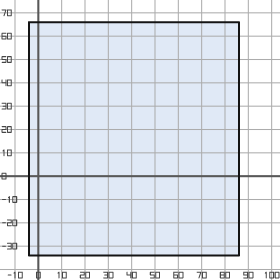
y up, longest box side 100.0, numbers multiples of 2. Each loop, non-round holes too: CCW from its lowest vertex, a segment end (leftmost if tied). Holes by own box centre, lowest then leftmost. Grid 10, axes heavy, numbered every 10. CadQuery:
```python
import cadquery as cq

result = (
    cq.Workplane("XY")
    .moveTo(-4.0, -34.0)
    .lineTo(86.0, -34.0)
    .lineTo(86.0, 66.0)
    .lineTo(-4.0, 66.0)
    .close()
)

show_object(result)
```